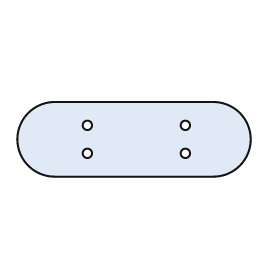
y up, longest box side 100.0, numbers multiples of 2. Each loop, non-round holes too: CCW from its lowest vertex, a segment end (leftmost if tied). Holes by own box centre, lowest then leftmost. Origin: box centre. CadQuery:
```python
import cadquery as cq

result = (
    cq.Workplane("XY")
    .moveTo(-34.0, -16.0)
    .lineTo(34.0, -16.0)
    .threePointArc((50.0, 0.0), (34.0, 16.0))
    .lineTo(-34.0, 16.0)
    .threePointArc((-50.0, 0.0), (-34.0, -16.0))
    .close()
    .moveTo(-20.0, -6.0)
    .circle(2.0)
    .moveTo(22.0, -6.0)
    .circle(2.0)
    .moveTo(-20.0, 6.0)
    .circle(2.0)
    .moveTo(22.0, 6.0)
    .circle(2.0)
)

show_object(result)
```